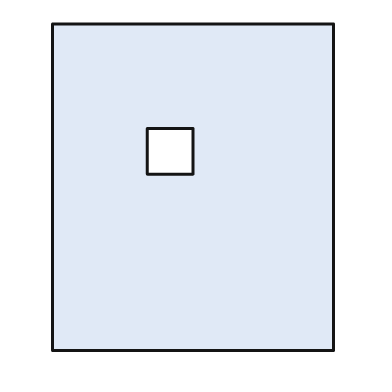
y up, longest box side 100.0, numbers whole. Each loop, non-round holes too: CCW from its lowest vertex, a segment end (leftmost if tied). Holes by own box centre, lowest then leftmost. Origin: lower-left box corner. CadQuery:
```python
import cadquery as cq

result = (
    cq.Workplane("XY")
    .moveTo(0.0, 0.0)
    .lineTo(86.0, 0.0)
    .lineTo(86.0, 100.0)
    .lineTo(0.0, 100.0)
    .close()
    .moveTo(29.0, 54.0)
    .lineTo(43.0, 54.0)
    .lineTo(43.0, 68.0)
    .lineTo(29.0, 68.0)
    .close()
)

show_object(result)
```